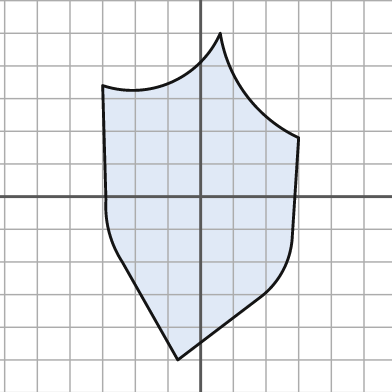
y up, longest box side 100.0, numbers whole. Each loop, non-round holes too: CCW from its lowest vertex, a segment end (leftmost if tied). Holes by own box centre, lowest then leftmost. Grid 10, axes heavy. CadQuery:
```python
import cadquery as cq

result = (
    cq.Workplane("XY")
    .moveTo(-7.0, -50.0)
    .lineTo(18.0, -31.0)
    .threePointArc((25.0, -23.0), (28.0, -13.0))
    .lineTo(30.0, 18.0)
    .threePointArc((14.0, 31.0), (6.0, 50.0))
    .threePointArc((-9.0, 35.0), (-30.0, 34.0))
    .lineTo(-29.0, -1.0)
    .threePointArc((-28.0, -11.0), (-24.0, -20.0))
    .close()
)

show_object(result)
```